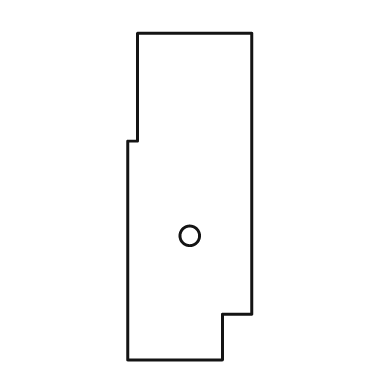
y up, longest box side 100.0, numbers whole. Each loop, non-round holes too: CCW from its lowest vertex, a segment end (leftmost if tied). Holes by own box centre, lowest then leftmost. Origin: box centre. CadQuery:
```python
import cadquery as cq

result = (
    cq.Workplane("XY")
    .moveTo(-19.0, -50.0)
    .lineTo(10.0, -50.0)
    .lineTo(10.0, -36.0)
    .lineTo(19.0, -36.0)
    .lineTo(19.0, 50.0)
    .lineTo(-16.0, 50.0)
    .lineTo(-16.0, 17.0)
    .lineTo(-19.0, 17.0)
    .close()
    .moveTo(0.0, -12.0)
    .circle(3.0)
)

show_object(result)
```